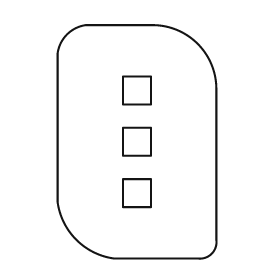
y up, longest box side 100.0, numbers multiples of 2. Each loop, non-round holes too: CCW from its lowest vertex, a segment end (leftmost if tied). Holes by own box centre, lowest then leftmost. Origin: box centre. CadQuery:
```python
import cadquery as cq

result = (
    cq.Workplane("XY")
    .moveTo(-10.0, -50.0)
    .lineTo(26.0, -50.0)
    .threePointArc((32.0, -48.0), (34.0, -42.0))
    .lineTo(34.0, 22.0)
    .threePointArc((26.0, 42.0), (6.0, 50.0))
    .lineTo(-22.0, 50.0)
    .threePointArc((-30.0, 46.0), (-34.0, 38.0))
    .lineTo(-34.0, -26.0)
    .threePointArc((-26.0, -42.0), (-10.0, -50.0))
    .close()
    .moveTo(-6.0, -28.0)
    .lineTo(6.0, -28.0)
    .lineTo(6.0, -16.0)
    .lineTo(-6.0, -16.0)
    .close()
    .moveTo(-6.0, -6.0)
    .lineTo(6.0, -6.0)
    .lineTo(6.0, 6.0)
    .lineTo(-6.0, 6.0)
    .close()
    .moveTo(-6.0, 16.0)
    .lineTo(6.0, 16.0)
    .lineTo(6.0, 28.0)
    .lineTo(-6.0, 28.0)
    .close()
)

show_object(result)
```